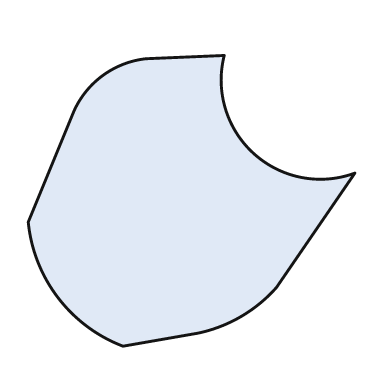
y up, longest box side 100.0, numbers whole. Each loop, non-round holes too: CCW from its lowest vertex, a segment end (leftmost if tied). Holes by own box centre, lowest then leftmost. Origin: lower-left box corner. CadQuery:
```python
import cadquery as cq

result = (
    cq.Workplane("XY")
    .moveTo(29.0, 0.0)
    .lineTo(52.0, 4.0)
    .threePointArc((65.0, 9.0), (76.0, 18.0))
    .lineTo(100.0, 53.0)
    .threePointArc((69.0, 59.0), (60.0, 89.0))
    .lineTo(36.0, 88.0)
    .threePointArc((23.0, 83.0), (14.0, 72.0))
    .lineTo(0.0, 38.0)
    .threePointArc((9.0, 15.0), (29.0, 0.0))
    .close()
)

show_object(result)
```